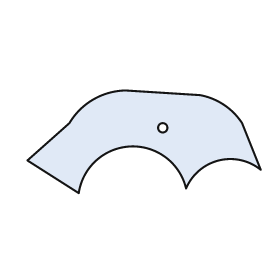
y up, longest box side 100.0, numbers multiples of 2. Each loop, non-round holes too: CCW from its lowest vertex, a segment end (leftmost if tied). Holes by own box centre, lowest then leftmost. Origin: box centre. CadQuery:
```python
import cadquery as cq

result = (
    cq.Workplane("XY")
    .moveTo(-28.0, -22.0)
    .threePointArc((-6.0, -2.0), (18.0, -20.0))
    .threePointArc((32.0, -8.0), (50.0, -12.0))
    .lineTo(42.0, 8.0)
    .threePointArc((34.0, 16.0), (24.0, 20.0))
    .lineTo(-8.0, 22.0)
    .threePointArc((-22.0, 18.0), (-32.0, 8.0))
    .lineTo(-50.0, -8.0)
    .close()
    .moveTo(8.0, 6.0)
    .circle(2.0)
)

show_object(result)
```